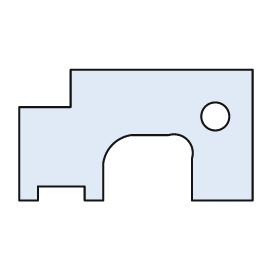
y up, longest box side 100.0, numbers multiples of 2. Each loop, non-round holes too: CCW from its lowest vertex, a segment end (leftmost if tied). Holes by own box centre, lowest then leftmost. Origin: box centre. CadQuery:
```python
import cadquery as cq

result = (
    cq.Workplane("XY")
    .moveTo(-50.0, -28.0)
    .lineTo(-42.0, -28.0)
    .lineTo(-42.0, -22.0)
    .lineTo(-22.0, -22.0)
    .lineTo(-22.0, -28.0)
    .lineTo(-14.0, -28.0)
    .lineTo(-14.0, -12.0)
    .threePointArc((-10.0, -4.0), (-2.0, 0.0))
    .lineTo(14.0, 0.0)
    .threePointArc((22.0, -2.0), (24.0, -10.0))
    .lineTo(24.0, -28.0)
    .lineTo(50.0, -28.0)
    .lineTo(50.0, 28.0)
    .lineTo(-28.0, 28.0)
    .lineTo(-28.0, 12.0)
    .lineTo(-50.0, 12.0)
    .close()
    .moveTo(34.0, 8.0)
    .circle(6.0)
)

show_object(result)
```